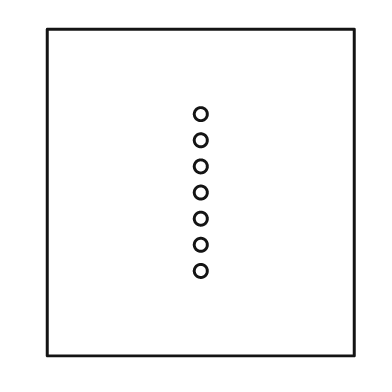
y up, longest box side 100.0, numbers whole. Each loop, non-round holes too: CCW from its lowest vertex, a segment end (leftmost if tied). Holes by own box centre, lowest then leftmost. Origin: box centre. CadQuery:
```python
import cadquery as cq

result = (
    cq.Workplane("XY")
    .moveTo(-47.0, -50.0)
    .lineTo(47.0, -50.0)
    .lineTo(47.0, 50.0)
    .lineTo(-47.0, 50.0)
    .close()
    .moveTo(0.0, -24.0)
    .circle(2.0)
    .moveTo(0.0, -16.0)
    .circle(2.0)
    .moveTo(0.0, -8.0)
    .circle(2.0)
    .moveTo(0.0, 0.0)
    .circle(2.0)
    .moveTo(0.0, 8.0)
    .circle(2.0)
    .moveTo(0.0, 16.0)
    .circle(2.0)
    .moveTo(0.0, 24.0)
    .circle(2.0)
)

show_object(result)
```